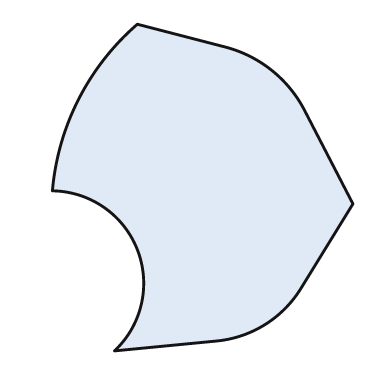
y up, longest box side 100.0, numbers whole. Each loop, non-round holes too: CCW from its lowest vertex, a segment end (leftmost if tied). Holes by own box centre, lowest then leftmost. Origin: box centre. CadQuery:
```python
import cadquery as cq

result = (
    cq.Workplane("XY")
    .moveTo(-27.0, -50.0)
    .lineTo(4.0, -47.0)
    .threePointArc((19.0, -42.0), (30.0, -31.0))
    .lineTo(46.0, -5.0)
    .lineTo(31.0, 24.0)
    .threePointArc((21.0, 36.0), (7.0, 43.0))
    .lineTo(-20.0, 50.0)
    .threePointArc((-38.0, 27.0), (-46.0, -1.0))
    .threePointArc((-20.0, -19.0), (-27.0, -50.0))
    .close()
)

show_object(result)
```